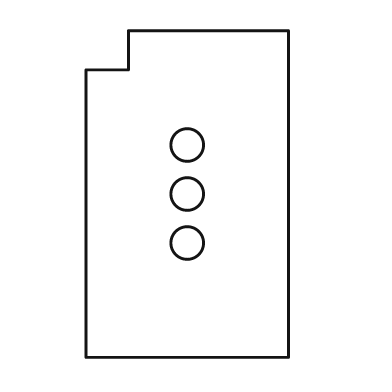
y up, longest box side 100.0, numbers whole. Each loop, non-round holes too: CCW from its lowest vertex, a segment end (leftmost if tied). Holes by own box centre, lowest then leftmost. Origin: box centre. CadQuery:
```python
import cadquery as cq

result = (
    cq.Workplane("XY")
    .moveTo(-31.0, -50.0)
    .lineTo(31.0, -50.0)
    .lineTo(31.0, 50.0)
    .lineTo(-18.0, 50.0)
    .lineTo(-18.0, 38.0)
    .lineTo(-31.0, 38.0)
    .close()
    .moveTo(0.0, -15.0)
    .circle(5.0)
    .moveTo(0.0, 0.0)
    .circle(5.0)
    .moveTo(0.0, 15.0)
    .circle(5.0)
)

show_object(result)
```